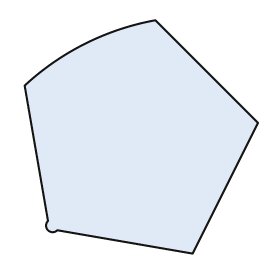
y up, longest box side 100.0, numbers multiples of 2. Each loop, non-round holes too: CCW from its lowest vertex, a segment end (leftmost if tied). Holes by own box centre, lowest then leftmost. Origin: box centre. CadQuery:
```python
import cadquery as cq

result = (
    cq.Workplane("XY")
    .moveTo(22.0, -50.0)
    .lineTo(50.0, 6.0)
    .lineTo(6.0, 50.0)
    .threePointArc((-24.0, 40.0), (-50.0, 22.0))
    .lineTo(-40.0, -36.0)
    .threePointArc((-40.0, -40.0), (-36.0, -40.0))
    .close()
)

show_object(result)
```